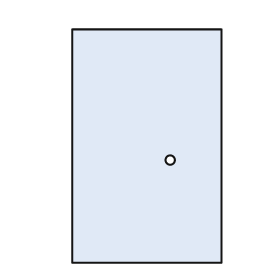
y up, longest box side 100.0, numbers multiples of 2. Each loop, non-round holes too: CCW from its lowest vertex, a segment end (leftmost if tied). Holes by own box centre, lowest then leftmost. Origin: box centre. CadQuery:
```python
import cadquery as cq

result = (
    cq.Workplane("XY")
    .moveTo(-32.0, -50.0)
    .lineTo(32.0, -50.0)
    .lineTo(32.0, 50.0)
    .lineTo(-32.0, 50.0)
    .close()
    .moveTo(10.0, -6.0)
    .circle(2.0)
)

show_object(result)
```